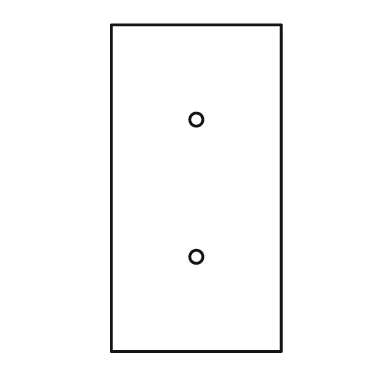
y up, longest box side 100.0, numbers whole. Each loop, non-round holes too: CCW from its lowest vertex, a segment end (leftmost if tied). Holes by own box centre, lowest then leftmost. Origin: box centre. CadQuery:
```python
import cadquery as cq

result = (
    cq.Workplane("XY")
    .moveTo(-26.0, -50.0)
    .lineTo(26.0, -50.0)
    .lineTo(26.0, 50.0)
    .lineTo(-26.0, 50.0)
    .close()
    .moveTo(0.0, -21.0)
    .circle(2.0)
    .moveTo(0.0, 21.0)
    .circle(2.0)
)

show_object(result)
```